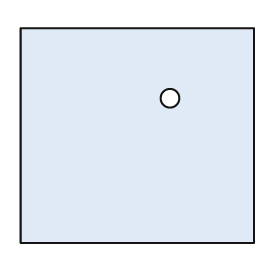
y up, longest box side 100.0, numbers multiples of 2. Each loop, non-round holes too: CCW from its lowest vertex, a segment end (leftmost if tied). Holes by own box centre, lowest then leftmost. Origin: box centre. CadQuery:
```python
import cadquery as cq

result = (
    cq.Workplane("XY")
    .moveTo(-50.0, -46.0)
    .lineTo(50.0, -46.0)
    .lineTo(50.0, 46.0)
    .lineTo(-50.0, 46.0)
    .close()
    .moveTo(14.0, 16.0)
    .circle(4.0)
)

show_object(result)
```